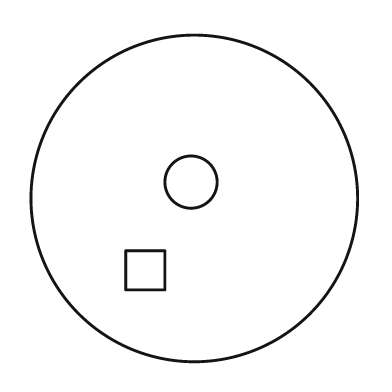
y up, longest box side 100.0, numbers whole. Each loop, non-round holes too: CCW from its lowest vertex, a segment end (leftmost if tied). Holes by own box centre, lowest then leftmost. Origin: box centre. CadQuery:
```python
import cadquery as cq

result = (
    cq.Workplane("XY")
    .moveTo(0.0, 0.0)
    .circle(50.0)
    .moveTo(-21.0, -28.0)
    .lineTo(-9.0, -28.0)
    .lineTo(-9.0, -16.0)
    .lineTo(-21.0, -16.0)
    .close()
    .moveTo(-1.0, 5.0)
    .circle(8.0)
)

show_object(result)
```